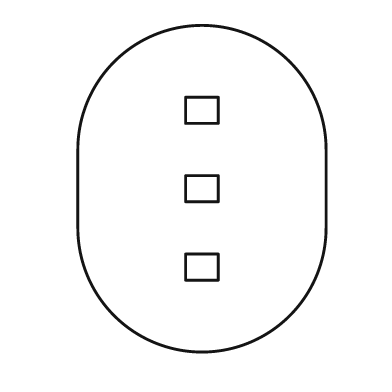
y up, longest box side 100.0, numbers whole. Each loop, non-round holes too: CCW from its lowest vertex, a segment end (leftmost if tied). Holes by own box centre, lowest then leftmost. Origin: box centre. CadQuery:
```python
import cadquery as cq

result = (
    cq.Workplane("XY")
    .moveTo(-38.0, -12.0)
    .threePointArc((0.0, -50.0), (38.0, -12.0))
    .lineTo(38.0, 12.0)
    .threePointArc((0.0, 50.0), (-38.0, 12.0))
    .close()
    .moveTo(-5.0, -28.0)
    .lineTo(5.0, -28.0)
    .lineTo(5.0, -20.0)
    .lineTo(-5.0, -20.0)
    .close()
    .moveTo(-5.0, -4.0)
    .lineTo(5.0, -4.0)
    .lineTo(5.0, 4.0)
    .lineTo(-5.0, 4.0)
    .close()
    .moveTo(-5.0, 20.0)
    .lineTo(5.0, 20.0)
    .lineTo(5.0, 28.0)
    .lineTo(-5.0, 28.0)
    .close()
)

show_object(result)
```